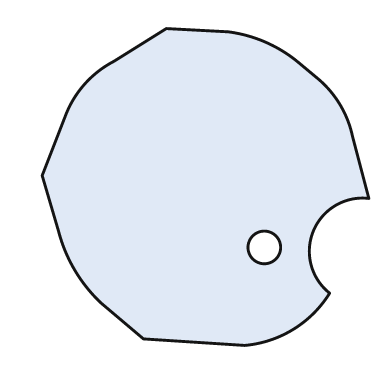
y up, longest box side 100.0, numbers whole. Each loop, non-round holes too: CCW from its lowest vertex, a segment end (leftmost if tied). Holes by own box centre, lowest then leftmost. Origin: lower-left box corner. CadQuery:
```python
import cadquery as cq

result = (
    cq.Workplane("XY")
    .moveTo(62.0, 0.0)
    .threePointArc((77.0, 5.0), (88.0, 16.0))
    .threePointArc((83.0, 35.0), (100.0, 45.0))
    .lineTo(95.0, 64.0)
    .threePointArc((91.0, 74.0), (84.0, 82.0))
    .lineTo(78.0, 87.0)
    .threePointArc((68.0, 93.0), (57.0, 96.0))
    .lineTo(38.0, 97.0)
    .lineTo(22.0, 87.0)
    .threePointArc((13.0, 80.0), (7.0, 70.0))
    .lineTo(0.0, 52.0)
    .lineTo(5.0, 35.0)
    .threePointArc((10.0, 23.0), (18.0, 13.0))
    .lineTo(31.0, 2.0)
    .close()
    .moveTo(68.0, 30.0)
    .circle(5.0)
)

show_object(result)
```